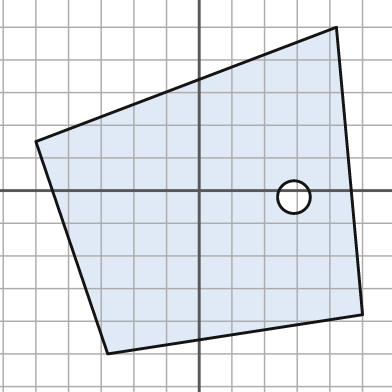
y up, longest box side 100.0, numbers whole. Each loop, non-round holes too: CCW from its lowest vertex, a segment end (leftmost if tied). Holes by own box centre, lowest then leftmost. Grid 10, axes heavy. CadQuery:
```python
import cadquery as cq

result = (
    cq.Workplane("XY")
    .moveTo(-28.0, -50.0)
    .lineTo(50.0, -38.0)
    .lineTo(42.0, 50.0)
    .lineTo(-50.0, 15.0)
    .close()
    .moveTo(29.0, -2.0)
    .circle(5.0)
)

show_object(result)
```